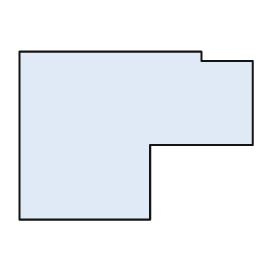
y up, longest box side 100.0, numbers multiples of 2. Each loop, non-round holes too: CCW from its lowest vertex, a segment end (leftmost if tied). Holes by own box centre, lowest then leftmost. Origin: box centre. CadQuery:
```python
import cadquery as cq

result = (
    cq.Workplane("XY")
    .moveTo(-50.0, -36.0)
    .lineTo(6.0, -36.0)
    .lineTo(6.0, -4.0)
    .lineTo(50.0, -4.0)
    .lineTo(50.0, 32.0)
    .lineTo(28.0, 32.0)
    .lineTo(28.0, 36.0)
    .lineTo(-50.0, 36.0)
    .close()
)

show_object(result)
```